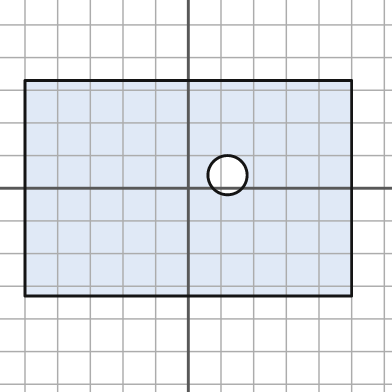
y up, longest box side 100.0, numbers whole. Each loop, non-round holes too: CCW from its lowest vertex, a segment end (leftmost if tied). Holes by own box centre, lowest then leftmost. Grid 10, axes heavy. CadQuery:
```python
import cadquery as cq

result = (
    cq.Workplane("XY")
    .moveTo(-50.0, -33.0)
    .lineTo(50.0, -33.0)
    .lineTo(50.0, 33.0)
    .lineTo(-50.0, 33.0)
    .close()
    .moveTo(12.0, 4.0)
    .circle(6.0)
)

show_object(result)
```